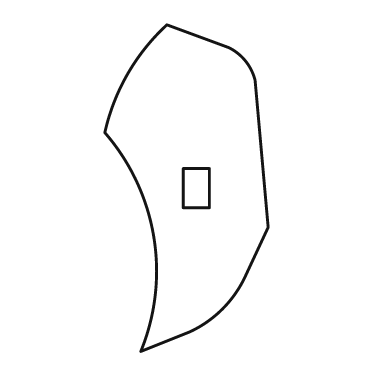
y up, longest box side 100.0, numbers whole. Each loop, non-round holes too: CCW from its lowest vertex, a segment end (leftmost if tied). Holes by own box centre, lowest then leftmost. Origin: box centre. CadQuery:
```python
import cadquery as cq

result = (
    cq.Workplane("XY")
    .moveTo(-14.0, -50.0)
    .lineTo(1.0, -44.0)
    .threePointArc((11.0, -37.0), (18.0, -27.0))
    .lineTo(25.0, -12.0)
    .lineTo(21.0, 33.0)
    .threePointArc((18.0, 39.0), (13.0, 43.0))
    .lineTo(-6.0, 50.0)
    .threePointArc((-18.0, 35.0), (-25.0, 17.0))
    .threePointArc((-10.0, -15.0), (-14.0, -50.0))
    .close()
    .moveTo(-1.0, -6.0)
    .lineTo(7.0, -6.0)
    .lineTo(7.0, 6.0)
    .lineTo(-1.0, 6.0)
    .close()
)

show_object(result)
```